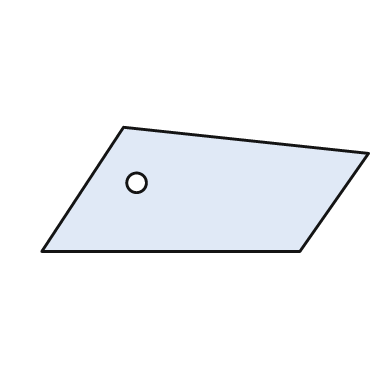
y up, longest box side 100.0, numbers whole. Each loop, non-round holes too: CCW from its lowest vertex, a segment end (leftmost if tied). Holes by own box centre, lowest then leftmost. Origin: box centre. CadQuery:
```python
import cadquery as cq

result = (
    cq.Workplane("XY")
    .moveTo(-50.0, -19.0)
    .lineTo(29.0, -19.0)
    .lineTo(50.0, 11.0)
    .lineTo(-25.0, 19.0)
    .close()
    .moveTo(-21.0, 2.0)
    .circle(3.0)
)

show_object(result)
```